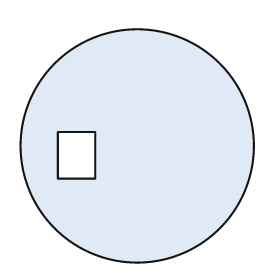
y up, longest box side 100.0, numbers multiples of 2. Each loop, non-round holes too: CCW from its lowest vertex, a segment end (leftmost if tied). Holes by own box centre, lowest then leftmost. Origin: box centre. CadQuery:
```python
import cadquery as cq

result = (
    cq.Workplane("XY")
    .moveTo(0.0, 0.0)
    .circle(50.0)
    .moveTo(-34.0, -14.0)
    .lineTo(-18.0, -14.0)
    .lineTo(-18.0, 6.0)
    .lineTo(-34.0, 6.0)
    .close()
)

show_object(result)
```